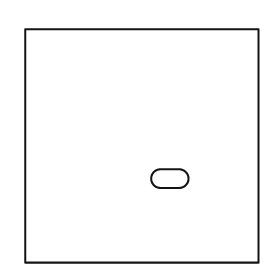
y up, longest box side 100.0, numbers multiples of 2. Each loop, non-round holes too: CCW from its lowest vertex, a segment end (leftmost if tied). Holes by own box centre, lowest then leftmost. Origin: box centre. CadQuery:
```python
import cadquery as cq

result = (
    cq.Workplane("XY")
    .moveTo(-50.0, -50.0)
    .lineTo(50.0, -50.0)
    .lineTo(50.0, 50.0)
    .lineTo(-50.0, 50.0)
    .close()
    .moveTo(8.0, -18.0)
    .lineTo(16.0, -18.0)
    .threePointArc((20.0, -14.0), (16.0, -10.0))
    .lineTo(8.0, -10.0)
    .threePointArc((4.0, -14.0), (8.0, -18.0))
    .close()
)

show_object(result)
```